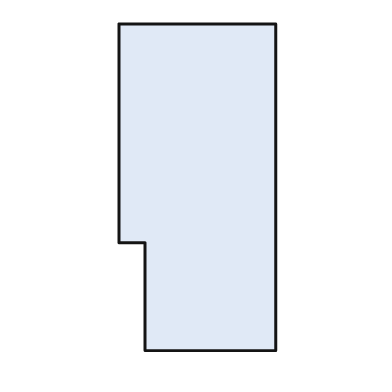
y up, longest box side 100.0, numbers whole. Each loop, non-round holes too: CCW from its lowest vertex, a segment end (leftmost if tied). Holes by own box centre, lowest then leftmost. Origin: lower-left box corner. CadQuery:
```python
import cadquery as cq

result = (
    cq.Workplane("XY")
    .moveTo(8.0, 0.0)
    .lineTo(48.0, 0.0)
    .lineTo(48.0, 100.0)
    .lineTo(0.0, 100.0)
    .lineTo(0.0, 33.0)
    .lineTo(8.0, 33.0)
    .close()
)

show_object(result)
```